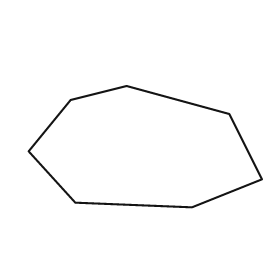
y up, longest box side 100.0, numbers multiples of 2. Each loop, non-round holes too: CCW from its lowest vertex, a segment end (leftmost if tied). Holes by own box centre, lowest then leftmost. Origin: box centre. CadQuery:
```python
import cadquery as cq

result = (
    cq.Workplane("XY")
    .moveTo(20.0, -26.0)
    .lineTo(50.0, -14.0)
    .lineTo(36.0, 14.0)
    .lineTo(-8.0, 26.0)
    .lineTo(-32.0, 20.0)
    .lineTo(-50.0, -2.0)
    .lineTo(-30.0, -24.0)
    .close()
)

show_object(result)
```